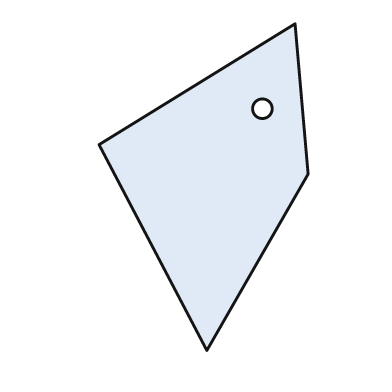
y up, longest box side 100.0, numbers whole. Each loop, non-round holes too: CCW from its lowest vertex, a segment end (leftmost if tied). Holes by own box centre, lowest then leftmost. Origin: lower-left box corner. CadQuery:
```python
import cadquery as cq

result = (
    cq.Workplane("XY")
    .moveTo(33.0, 0.0)
    .lineTo(64.0, 54.0)
    .lineTo(60.0, 100.0)
    .lineTo(0.0, 63.0)
    .close()
    .moveTo(50.0, 74.0)
    .circle(3.0)
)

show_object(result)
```